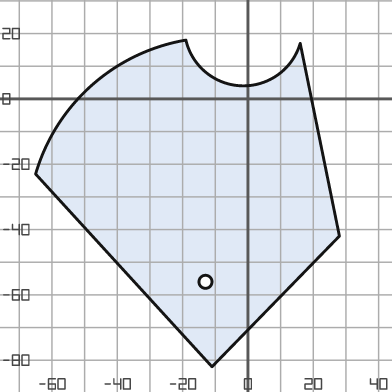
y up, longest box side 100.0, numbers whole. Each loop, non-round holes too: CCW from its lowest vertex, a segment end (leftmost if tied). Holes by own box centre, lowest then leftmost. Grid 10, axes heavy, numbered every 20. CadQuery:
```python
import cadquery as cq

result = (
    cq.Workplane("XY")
    .moveTo(-11.0, -82.0)
    .lineTo(28.0, -42.0)
    .lineTo(16.0, 17.0)
    .threePointArc((-2.0, 4.0), (-19.0, 18.0))
    .threePointArc((-48.0, 4.0), (-65.0, -23.0))
    .close()
    .moveTo(-13.0, -56.0)
    .circle(2.0)
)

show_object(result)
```